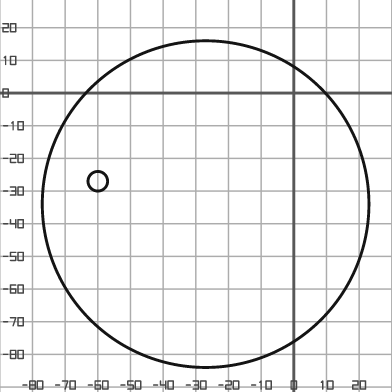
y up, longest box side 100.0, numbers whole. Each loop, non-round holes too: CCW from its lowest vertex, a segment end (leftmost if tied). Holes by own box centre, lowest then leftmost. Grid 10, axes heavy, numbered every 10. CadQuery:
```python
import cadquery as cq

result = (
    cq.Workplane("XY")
    .moveTo(-27.0, -34.0)
    .circle(50.0)
    .moveTo(-60.0, -27.0)
    .circle(3.0)
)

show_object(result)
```